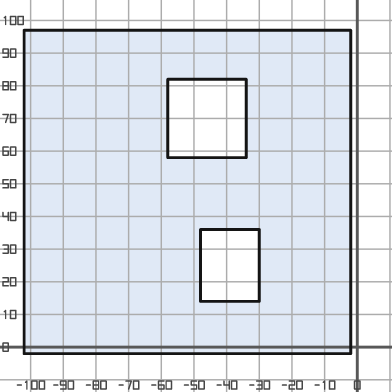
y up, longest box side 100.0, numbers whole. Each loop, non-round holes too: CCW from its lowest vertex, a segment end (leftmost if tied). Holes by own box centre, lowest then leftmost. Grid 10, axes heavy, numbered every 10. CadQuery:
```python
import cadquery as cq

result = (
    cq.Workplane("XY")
    .moveTo(-102.0, -2.0)
    .lineTo(-2.0, -2.0)
    .lineTo(-2.0, 97.0)
    .lineTo(-102.0, 97.0)
    .close()
    .moveTo(-48.0, 14.0)
    .lineTo(-30.0, 14.0)
    .lineTo(-30.0, 36.0)
    .lineTo(-48.0, 36.0)
    .close()
    .moveTo(-58.0, 58.0)
    .lineTo(-34.0, 58.0)
    .lineTo(-34.0, 82.0)
    .lineTo(-58.0, 82.0)
    .close()
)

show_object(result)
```